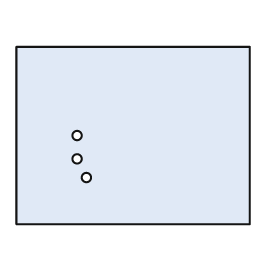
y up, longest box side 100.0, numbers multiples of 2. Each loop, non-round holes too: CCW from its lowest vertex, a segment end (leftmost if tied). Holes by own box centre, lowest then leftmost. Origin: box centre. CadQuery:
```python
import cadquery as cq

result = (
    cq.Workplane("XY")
    .moveTo(-50.0, -38.0)
    .lineTo(50.0, -38.0)
    .lineTo(50.0, 38.0)
    .lineTo(-50.0, 38.0)
    .close()
    .moveTo(-20.0, -18.0)
    .circle(2.0)
    .moveTo(-24.0, -10.0)
    .circle(2.0)
    .moveTo(-24.0, 0.0)
    .circle(2.0)
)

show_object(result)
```